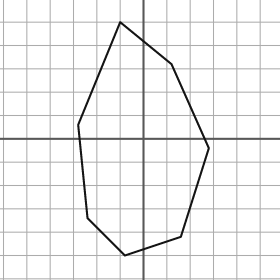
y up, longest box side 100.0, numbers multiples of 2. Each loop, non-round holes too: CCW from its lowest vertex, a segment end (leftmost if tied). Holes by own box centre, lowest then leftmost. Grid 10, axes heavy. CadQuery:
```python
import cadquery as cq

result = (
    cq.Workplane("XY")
    .moveTo(-8.0, -50.0)
    .lineTo(16.0, -42.0)
    .lineTo(28.0, -4.0)
    .lineTo(12.0, 32.0)
    .lineTo(-10.0, 50.0)
    .lineTo(-28.0, 6.0)
    .lineTo(-24.0, -34.0)
    .close()
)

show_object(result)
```